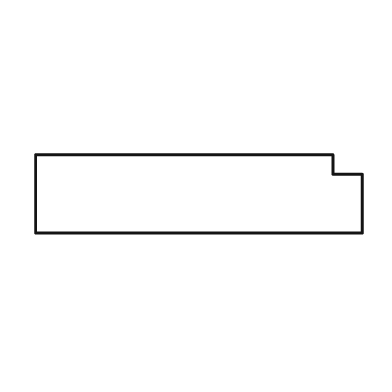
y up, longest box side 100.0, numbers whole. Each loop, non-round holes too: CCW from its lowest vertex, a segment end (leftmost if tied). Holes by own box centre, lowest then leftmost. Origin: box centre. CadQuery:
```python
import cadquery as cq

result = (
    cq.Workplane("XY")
    .moveTo(-50.0, -12.0)
    .lineTo(50.0, -12.0)
    .lineTo(50.0, 6.0)
    .lineTo(41.0, 6.0)
    .lineTo(41.0, 12.0)
    .lineTo(-50.0, 12.0)
    .close()
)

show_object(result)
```